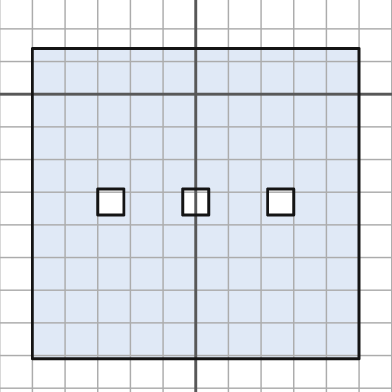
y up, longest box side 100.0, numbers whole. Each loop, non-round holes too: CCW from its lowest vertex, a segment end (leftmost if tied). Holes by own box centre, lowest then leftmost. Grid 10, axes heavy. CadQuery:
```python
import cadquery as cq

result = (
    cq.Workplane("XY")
    .moveTo(-50.0, -81.0)
    .lineTo(50.0, -81.0)
    .lineTo(50.0, 14.0)
    .lineTo(-50.0, 14.0)
    .close()
    .moveTo(-30.0, -37.0)
    .lineTo(-22.0, -37.0)
    .lineTo(-22.0, -29.0)
    .lineTo(-30.0, -29.0)
    .close()
    .moveTo(-4.0, -37.0)
    .lineTo(4.0, -37.0)
    .lineTo(4.0, -29.0)
    .lineTo(-4.0, -29.0)
    .close()
    .moveTo(22.0, -37.0)
    .lineTo(30.0, -37.0)
    .lineTo(30.0, -29.0)
    .lineTo(22.0, -29.0)
    .close()
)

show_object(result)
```